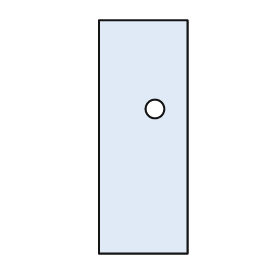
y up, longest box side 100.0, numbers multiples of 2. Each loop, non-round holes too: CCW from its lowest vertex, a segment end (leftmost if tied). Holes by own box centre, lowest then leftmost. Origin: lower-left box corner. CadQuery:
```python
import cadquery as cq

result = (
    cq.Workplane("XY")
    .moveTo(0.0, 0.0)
    .lineTo(38.0, 0.0)
    .lineTo(38.0, 100.0)
    .lineTo(0.0, 100.0)
    .close()
    .moveTo(24.0, 62.0)
    .circle(4.0)
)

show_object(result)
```